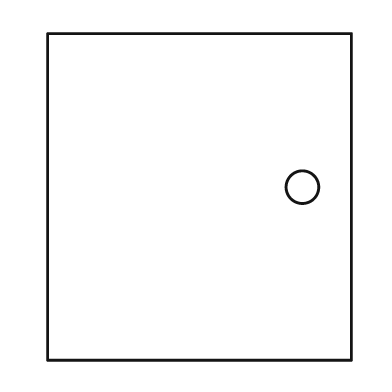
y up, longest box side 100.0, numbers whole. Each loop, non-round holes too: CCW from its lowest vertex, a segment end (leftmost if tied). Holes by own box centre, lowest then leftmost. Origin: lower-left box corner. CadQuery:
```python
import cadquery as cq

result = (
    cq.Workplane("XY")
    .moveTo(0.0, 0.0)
    .lineTo(93.0, 0.0)
    .lineTo(93.0, 100.0)
    .lineTo(0.0, 100.0)
    .close()
    .moveTo(78.0, 53.0)
    .circle(5.0)
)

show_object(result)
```